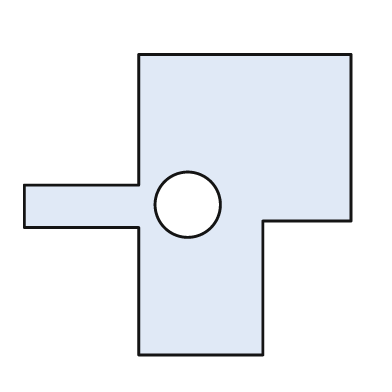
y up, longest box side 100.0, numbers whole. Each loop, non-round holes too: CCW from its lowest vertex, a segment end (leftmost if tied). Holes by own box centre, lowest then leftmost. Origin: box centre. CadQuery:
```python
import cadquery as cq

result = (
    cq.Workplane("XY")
    .moveTo(-15.0, -46.0)
    .lineTo(23.0, -46.0)
    .lineTo(23.0, -5.0)
    .lineTo(50.0, -5.0)
    .lineTo(50.0, 46.0)
    .lineTo(-15.0, 46.0)
    .lineTo(-15.0, 6.0)
    .lineTo(-50.0, 6.0)
    .lineTo(-50.0, -7.0)
    .lineTo(-15.0, -7.0)
    .close()
    .moveTo(0.0, 0.0)
    .circle(10.0)
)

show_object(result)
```